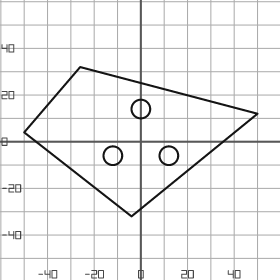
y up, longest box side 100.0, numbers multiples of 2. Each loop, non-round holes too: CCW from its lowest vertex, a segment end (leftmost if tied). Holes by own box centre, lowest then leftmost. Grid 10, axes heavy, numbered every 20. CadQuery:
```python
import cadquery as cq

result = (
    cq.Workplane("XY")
    .moveTo(-4.0, -32.0)
    .lineTo(50.0, 12.0)
    .lineTo(-26.0, 32.0)
    .lineTo(-50.0, 4.0)
    .close()
    .moveTo(-12.0, -6.0)
    .circle(4.0)
    .moveTo(12.0, -6.0)
    .circle(4.0)
    .moveTo(0.0, 14.0)
    .circle(4.0)
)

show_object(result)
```